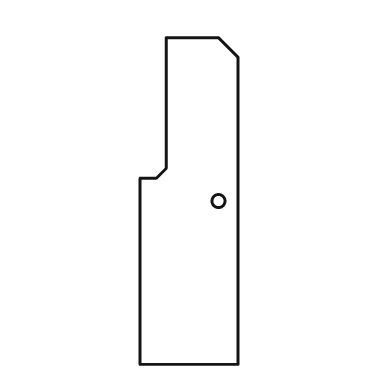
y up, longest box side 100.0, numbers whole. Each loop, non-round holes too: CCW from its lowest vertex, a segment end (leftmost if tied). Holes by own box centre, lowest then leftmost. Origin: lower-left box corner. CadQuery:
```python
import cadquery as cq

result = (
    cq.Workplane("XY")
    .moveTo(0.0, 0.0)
    .lineTo(30.0, 0.0)
    .lineTo(30.0, 94.0)
    .lineTo(24.0, 100.0)
    .lineTo(8.0, 100.0)
    .lineTo(8.0, 60.0)
    .lineTo(5.0, 57.0)
    .lineTo(0.0, 57.0)
    .close()
    .moveTo(24.0, 50.0)
    .circle(2.0)
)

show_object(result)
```